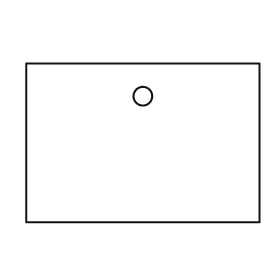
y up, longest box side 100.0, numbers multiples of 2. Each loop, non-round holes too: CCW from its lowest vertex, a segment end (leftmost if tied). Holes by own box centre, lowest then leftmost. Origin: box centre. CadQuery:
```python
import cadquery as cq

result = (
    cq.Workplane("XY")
    .moveTo(-50.0, -34.0)
    .lineTo(50.0, -34.0)
    .lineTo(50.0, 34.0)
    .lineTo(-50.0, 34.0)
    .close()
    .moveTo(0.0, 20.0)
    .circle(4.0)
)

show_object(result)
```